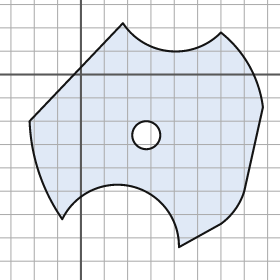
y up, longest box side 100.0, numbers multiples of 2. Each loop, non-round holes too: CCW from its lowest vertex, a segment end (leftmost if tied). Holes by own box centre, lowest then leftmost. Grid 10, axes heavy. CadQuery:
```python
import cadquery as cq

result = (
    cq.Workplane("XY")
    .moveTo(42.0, -74.0)
    .lineTo(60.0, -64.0)
    .threePointArc((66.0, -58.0), (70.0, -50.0))
    .lineTo(78.0, -14.0)
    .threePointArc((72.0, 4.0), (60.0, 18.0))
    .threePointArc((38.0, 10.0), (18.0, 22.0))
    .lineTo(-22.0, -20.0)
    .threePointArc((-18.0, -42.0), (-8.0, -62.0))
    .threePointArc((22.0, -48.0), (42.0, -74.0))
    .close()
    .moveTo(28.0, -26.0)
    .circle(6.0)
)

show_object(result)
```